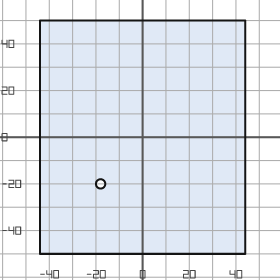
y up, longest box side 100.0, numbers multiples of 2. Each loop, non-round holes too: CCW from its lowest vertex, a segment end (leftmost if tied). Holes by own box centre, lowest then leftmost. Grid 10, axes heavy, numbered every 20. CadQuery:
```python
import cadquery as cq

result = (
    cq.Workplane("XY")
    .moveTo(-44.0, -50.0)
    .lineTo(44.0, -50.0)
    .lineTo(44.0, 50.0)
    .lineTo(-44.0, 50.0)
    .close()
    .moveTo(-18.0, -20.0)
    .circle(2.0)
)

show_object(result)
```